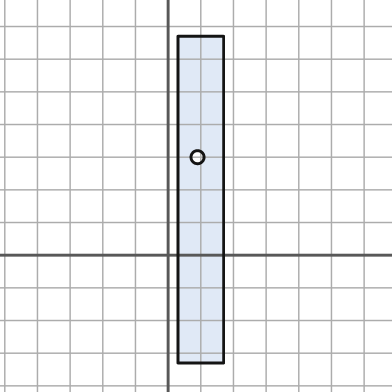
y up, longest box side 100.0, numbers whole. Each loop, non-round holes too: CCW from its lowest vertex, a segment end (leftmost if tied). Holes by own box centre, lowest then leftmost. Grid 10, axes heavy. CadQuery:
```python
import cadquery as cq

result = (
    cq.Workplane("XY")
    .moveTo(3.0, -33.0)
    .lineTo(17.0, -33.0)
    .lineTo(17.0, 67.0)
    .lineTo(3.0, 67.0)
    .close()
    .moveTo(9.0, 30.0)
    .circle(2.0)
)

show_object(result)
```